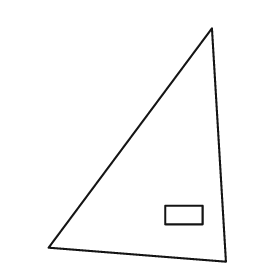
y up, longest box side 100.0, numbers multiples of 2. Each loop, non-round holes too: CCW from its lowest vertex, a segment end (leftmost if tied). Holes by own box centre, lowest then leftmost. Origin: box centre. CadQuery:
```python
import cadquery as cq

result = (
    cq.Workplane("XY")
    .moveTo(38.0, -50.0)
    .lineTo(32.0, 50.0)
    .lineTo(-38.0, -44.0)
    .close()
    .moveTo(12.0, -34.0)
    .lineTo(28.0, -34.0)
    .lineTo(28.0, -26.0)
    .lineTo(12.0, -26.0)
    .close()
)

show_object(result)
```